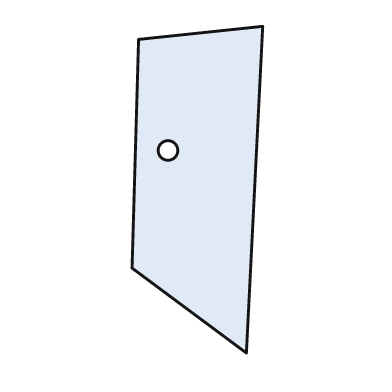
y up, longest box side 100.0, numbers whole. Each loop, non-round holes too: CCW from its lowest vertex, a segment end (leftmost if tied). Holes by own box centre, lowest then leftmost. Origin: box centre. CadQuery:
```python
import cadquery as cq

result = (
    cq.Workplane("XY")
    .moveTo(15.0, -50.0)
    .lineTo(20.0, 50.0)
    .lineTo(-18.0, 46.0)
    .lineTo(-20.0, -24.0)
    .close()
    .moveTo(-9.0, 12.0)
    .circle(3.0)
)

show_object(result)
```